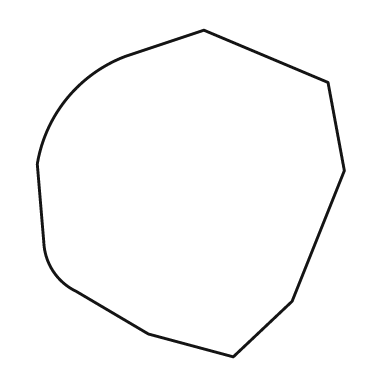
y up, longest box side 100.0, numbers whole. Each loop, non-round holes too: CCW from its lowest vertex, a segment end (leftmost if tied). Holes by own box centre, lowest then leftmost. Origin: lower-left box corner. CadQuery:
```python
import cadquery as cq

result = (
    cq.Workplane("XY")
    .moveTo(60.0, 0.0)
    .lineTo(78.0, 17.0)
    .lineTo(94.0, 57.0)
    .lineTo(89.0, 84.0)
    .lineTo(51.0, 100.0)
    .lineTo(27.0, 92.0)
    .threePointArc((9.0, 79.0), (0.0, 59.0))
    .lineTo(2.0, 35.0)
    .threePointArc((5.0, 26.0), (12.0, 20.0))
    .lineTo(34.0, 7.0)
    .close()
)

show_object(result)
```